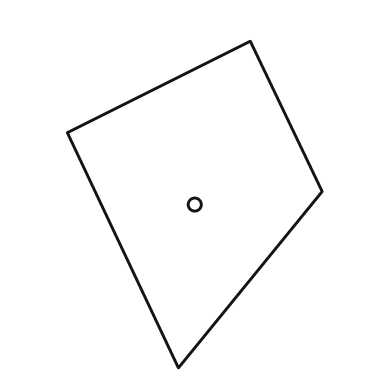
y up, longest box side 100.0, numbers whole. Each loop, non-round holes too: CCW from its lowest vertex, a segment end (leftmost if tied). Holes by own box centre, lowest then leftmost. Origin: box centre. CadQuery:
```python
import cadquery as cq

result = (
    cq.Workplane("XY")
    .moveTo(-5.0, -50.0)
    .lineTo(39.0, 4.0)
    .lineTo(17.0, 50.0)
    .lineTo(-39.0, 22.0)
    .close()
    .moveTo(0.0, 0.0)
    .circle(2.0)
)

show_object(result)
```